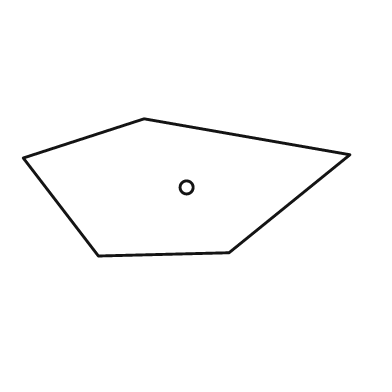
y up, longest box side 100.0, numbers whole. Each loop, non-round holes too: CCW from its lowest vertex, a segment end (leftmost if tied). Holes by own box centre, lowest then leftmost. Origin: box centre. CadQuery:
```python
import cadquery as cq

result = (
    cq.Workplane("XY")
    .moveTo(-27.0, -21.0)
    .lineTo(13.0, -20.0)
    .lineTo(50.0, 10.0)
    .lineTo(-13.0, 21.0)
    .lineTo(-50.0, 9.0)
    .close()
    .moveTo(0.0, 0.0)
    .circle(2.0)
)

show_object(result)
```